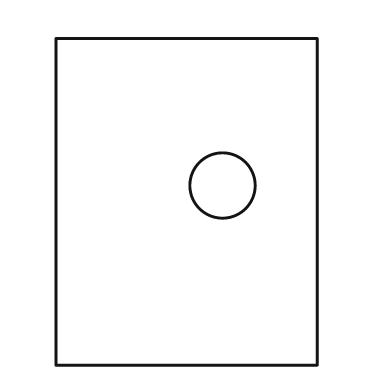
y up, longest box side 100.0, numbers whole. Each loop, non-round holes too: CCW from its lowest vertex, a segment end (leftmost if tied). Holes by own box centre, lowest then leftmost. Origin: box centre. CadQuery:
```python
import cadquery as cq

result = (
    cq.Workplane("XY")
    .moveTo(-40.0, -50.0)
    .lineTo(40.0, -50.0)
    .lineTo(40.0, 50.0)
    .lineTo(-40.0, 50.0)
    .close()
    .moveTo(11.0, 5.0)
    .circle(10.0)
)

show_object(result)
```